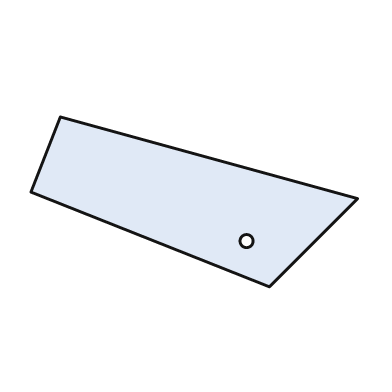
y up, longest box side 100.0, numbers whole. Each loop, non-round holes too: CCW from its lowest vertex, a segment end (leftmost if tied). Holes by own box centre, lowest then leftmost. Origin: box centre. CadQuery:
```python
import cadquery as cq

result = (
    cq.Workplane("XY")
    .moveTo(23.0, -26.0)
    .lineTo(50.0, 1.0)
    .lineTo(-41.0, 26.0)
    .lineTo(-50.0, 3.0)
    .close()
    .moveTo(16.0, -12.0)
    .circle(2.0)
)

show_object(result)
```